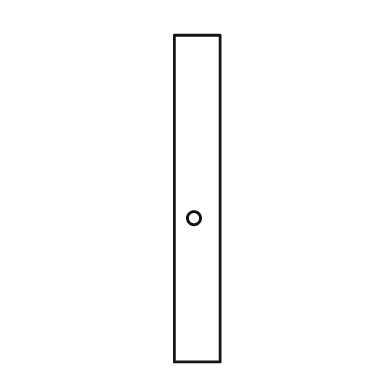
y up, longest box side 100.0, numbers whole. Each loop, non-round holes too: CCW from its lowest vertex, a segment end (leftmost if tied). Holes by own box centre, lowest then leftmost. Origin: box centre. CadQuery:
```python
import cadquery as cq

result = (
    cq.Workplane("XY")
    .moveTo(-7.0, -50.0)
    .lineTo(7.0, -50.0)
    .lineTo(7.0, 50.0)
    .lineTo(-7.0, 50.0)
    .close()
    .moveTo(-1.0, -6.0)
    .circle(2.0)
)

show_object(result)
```